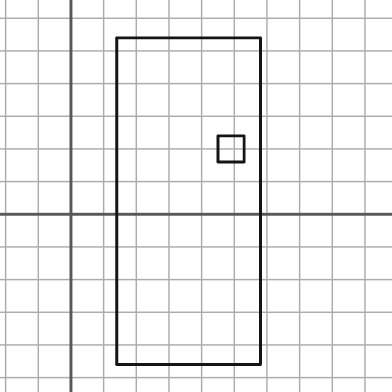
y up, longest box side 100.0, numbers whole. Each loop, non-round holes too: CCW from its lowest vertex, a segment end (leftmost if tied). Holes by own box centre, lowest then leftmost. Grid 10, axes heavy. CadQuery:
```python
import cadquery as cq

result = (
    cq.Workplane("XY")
    .moveTo(14.0, -46.0)
    .lineTo(58.0, -46.0)
    .lineTo(58.0, 54.0)
    .lineTo(14.0, 54.0)
    .close()
    .moveTo(45.0, 16.0)
    .lineTo(53.0, 16.0)
    .lineTo(53.0, 24.0)
    .lineTo(45.0, 24.0)
    .close()
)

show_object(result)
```